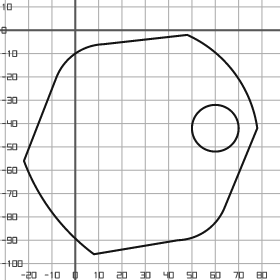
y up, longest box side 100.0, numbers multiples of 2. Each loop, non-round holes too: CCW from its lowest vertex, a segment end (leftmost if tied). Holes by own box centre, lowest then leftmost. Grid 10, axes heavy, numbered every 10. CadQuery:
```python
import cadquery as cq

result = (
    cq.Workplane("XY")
    .moveTo(8.0, -96.0)
    .lineTo(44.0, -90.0)
    .threePointArc((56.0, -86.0), (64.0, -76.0))
    .lineTo(78.0, -42.0)
    .threePointArc((68.0, -18.0), (48.0, -2.0))
    .lineTo(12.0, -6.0)
    .threePointArc((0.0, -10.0), (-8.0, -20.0))
    .lineTo(-22.0, -56.0)
    .threePointArc((-10.0, -78.0), (8.0, -96.0))
    .close()
    .moveTo(60.0, -42.0)
    .circle(10.0)
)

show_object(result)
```